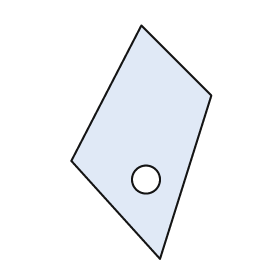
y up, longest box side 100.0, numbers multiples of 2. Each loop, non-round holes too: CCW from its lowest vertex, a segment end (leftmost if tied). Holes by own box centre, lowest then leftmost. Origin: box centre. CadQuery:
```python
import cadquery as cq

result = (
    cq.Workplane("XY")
    .moveTo(8.0, -50.0)
    .lineTo(30.0, 20.0)
    .lineTo(0.0, 50.0)
    .lineTo(-30.0, -8.0)
    .close()
    .moveTo(2.0, -16.0)
    .circle(6.0)
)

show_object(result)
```